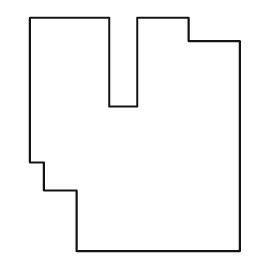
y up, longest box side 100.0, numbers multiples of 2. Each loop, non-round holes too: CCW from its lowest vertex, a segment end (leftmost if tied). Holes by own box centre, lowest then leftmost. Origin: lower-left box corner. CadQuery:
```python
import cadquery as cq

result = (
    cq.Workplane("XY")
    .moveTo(20.0, 0.0)
    .lineTo(90.0, 0.0)
    .lineTo(90.0, 90.0)
    .lineTo(68.0, 90.0)
    .lineTo(68.0, 100.0)
    .lineTo(46.0, 100.0)
    .lineTo(46.0, 62.0)
    .lineTo(34.0, 62.0)
    .lineTo(34.0, 100.0)
    .lineTo(0.0, 100.0)
    .lineTo(0.0, 38.0)
    .lineTo(6.0, 38.0)
    .lineTo(6.0, 26.0)
    .lineTo(20.0, 26.0)
    .close()
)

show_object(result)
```